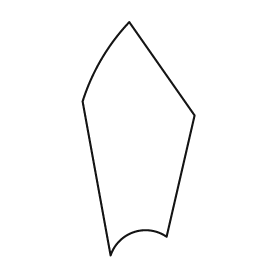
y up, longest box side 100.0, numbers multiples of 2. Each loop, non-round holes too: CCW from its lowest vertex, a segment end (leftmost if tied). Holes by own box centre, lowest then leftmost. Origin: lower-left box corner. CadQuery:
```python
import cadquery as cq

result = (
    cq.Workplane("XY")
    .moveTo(12.0, 0.0)
    .threePointArc((22.0, 10.0), (36.0, 8.0))
    .lineTo(48.0, 60.0)
    .lineTo(20.0, 100.0)
    .threePointArc((8.0, 84.0), (0.0, 66.0))
    .close()
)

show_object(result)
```